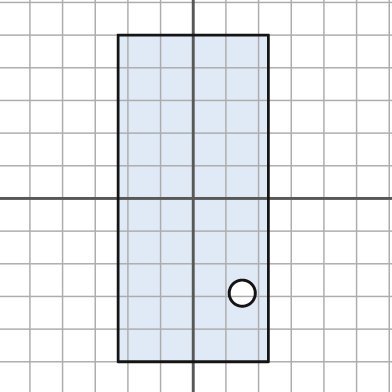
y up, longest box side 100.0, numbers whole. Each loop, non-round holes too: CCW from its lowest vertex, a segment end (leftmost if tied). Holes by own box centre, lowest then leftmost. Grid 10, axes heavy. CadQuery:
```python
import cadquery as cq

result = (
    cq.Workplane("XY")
    .moveTo(-23.0, -50.0)
    .lineTo(23.0, -50.0)
    .lineTo(23.0, 50.0)
    .lineTo(-23.0, 50.0)
    .close()
    .moveTo(15.0, -29.0)
    .circle(4.0)
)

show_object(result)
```